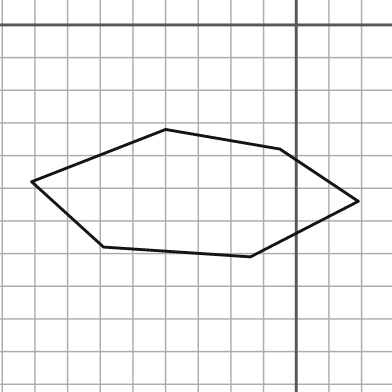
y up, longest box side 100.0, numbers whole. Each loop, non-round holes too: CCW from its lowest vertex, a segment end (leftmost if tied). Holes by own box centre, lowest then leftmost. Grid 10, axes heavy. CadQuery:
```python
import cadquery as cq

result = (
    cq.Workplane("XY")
    .moveTo(-14.0, -71.0)
    .lineTo(19.0, -54.0)
    .lineTo(-5.0, -38.0)
    .lineTo(-40.0, -32.0)
    .lineTo(-81.0, -48.0)
    .lineTo(-59.0, -68.0)
    .close()
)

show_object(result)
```